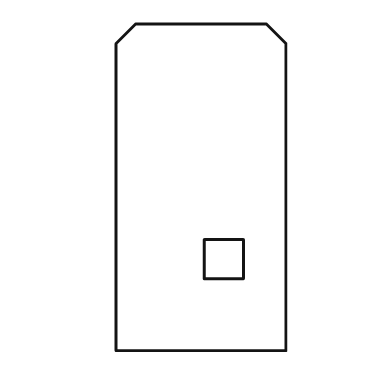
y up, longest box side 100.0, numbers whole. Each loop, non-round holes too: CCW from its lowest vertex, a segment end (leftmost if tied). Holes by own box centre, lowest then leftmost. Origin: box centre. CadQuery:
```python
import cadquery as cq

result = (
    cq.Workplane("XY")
    .moveTo(-26.0, -50.0)
    .lineTo(26.0, -50.0)
    .lineTo(26.0, 44.0)
    .lineTo(20.0, 50.0)
    .lineTo(-20.0, 50.0)
    .lineTo(-26.0, 44.0)
    .close()
    .moveTo(1.0, -28.0)
    .lineTo(13.0, -28.0)
    .lineTo(13.0, -16.0)
    .lineTo(1.0, -16.0)
    .close()
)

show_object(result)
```